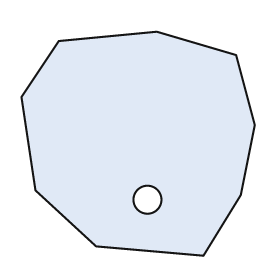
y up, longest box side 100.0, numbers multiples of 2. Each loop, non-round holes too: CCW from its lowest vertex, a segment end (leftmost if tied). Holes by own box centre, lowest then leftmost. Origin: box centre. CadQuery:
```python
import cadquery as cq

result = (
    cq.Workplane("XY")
    .moveTo(28.0, -48.0)
    .lineTo(44.0, -22.0)
    .lineTo(50.0, 8.0)
    .lineTo(42.0, 38.0)
    .lineTo(8.0, 48.0)
    .lineTo(-34.0, 44.0)
    .lineTo(-50.0, 20.0)
    .lineTo(-44.0, -20.0)
    .lineTo(-18.0, -44.0)
    .close()
    .moveTo(4.0, -24.0)
    .circle(6.0)
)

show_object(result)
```